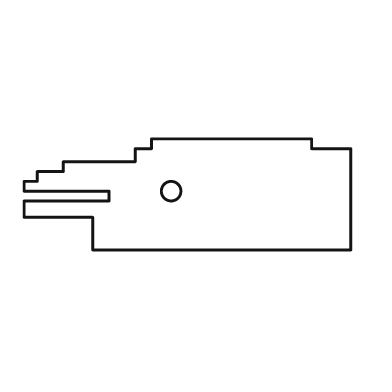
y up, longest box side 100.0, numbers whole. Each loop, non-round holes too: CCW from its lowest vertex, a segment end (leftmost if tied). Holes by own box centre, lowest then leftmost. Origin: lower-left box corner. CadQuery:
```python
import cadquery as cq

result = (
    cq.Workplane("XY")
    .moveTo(21.0, 0.0)
    .lineTo(100.0, 0.0)
    .lineTo(100.0, 31.0)
    .lineTo(88.0, 31.0)
    .lineTo(88.0, 34.0)
    .lineTo(39.0, 34.0)
    .lineTo(39.0, 31.0)
    .lineTo(34.0, 31.0)
    .lineTo(34.0, 27.0)
    .lineTo(12.0, 27.0)
    .lineTo(12.0, 24.0)
    .lineTo(4.0, 24.0)
    .lineTo(4.0, 21.0)
    .lineTo(0.0, 21.0)
    .lineTo(0.0, 18.0)
    .lineTo(26.0, 18.0)
    .lineTo(26.0, 15.0)
    .lineTo(0.0, 15.0)
    .lineTo(0.0, 10.0)
    .lineTo(21.0, 10.0)
    .close()
    .moveTo(45.0, 18.0)
    .circle(3.0)
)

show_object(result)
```